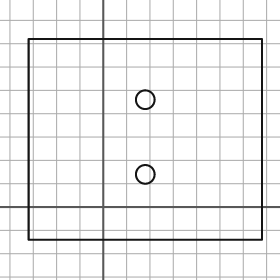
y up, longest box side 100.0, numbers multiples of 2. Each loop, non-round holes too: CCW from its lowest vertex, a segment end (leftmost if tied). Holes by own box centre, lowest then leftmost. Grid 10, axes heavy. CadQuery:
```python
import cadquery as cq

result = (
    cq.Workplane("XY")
    .moveTo(-32.0, -14.0)
    .lineTo(68.0, -14.0)
    .lineTo(68.0, 72.0)
    .lineTo(-32.0, 72.0)
    .close()
    .moveTo(18.0, 14.0)
    .circle(4.0)
    .moveTo(18.0, 46.0)
    .circle(4.0)
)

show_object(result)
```